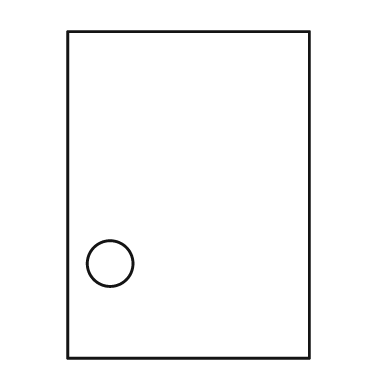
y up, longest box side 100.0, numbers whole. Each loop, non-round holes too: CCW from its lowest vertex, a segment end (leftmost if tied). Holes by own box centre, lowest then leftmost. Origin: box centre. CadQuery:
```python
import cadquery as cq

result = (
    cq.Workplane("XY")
    .moveTo(-37.0, -50.0)
    .lineTo(37.0, -50.0)
    .lineTo(37.0, 50.0)
    .lineTo(-37.0, 50.0)
    .close()
    .moveTo(-24.0, -21.0)
    .circle(7.0)
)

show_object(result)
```